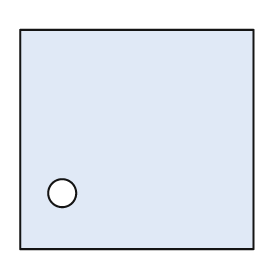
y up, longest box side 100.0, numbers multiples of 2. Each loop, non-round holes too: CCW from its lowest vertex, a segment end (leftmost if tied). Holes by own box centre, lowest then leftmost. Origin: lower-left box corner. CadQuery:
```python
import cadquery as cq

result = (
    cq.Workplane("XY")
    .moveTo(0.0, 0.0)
    .lineTo(100.0, 0.0)
    .lineTo(100.0, 94.0)
    .lineTo(0.0, 94.0)
    .close()
    .moveTo(18.0, 24.0)
    .circle(6.0)
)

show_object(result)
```